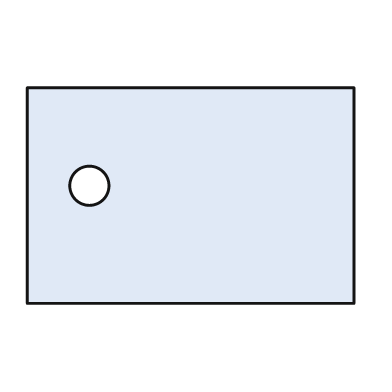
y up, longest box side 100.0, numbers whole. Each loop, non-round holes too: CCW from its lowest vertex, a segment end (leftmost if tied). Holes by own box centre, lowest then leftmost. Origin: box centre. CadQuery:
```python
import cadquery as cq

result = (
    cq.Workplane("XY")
    .moveTo(-50.0, -33.0)
    .lineTo(50.0, -33.0)
    .lineTo(50.0, 33.0)
    .lineTo(-50.0, 33.0)
    .close()
    .moveTo(-31.0, 3.0)
    .circle(6.0)
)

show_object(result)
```